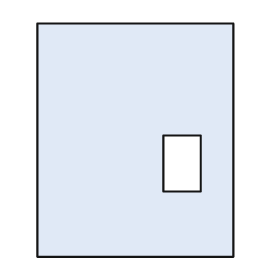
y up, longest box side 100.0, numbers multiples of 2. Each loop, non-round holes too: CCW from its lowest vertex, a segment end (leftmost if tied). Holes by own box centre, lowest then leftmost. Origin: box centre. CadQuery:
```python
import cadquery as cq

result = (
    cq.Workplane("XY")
    .moveTo(-42.0, -50.0)
    .lineTo(42.0, -50.0)
    .lineTo(42.0, 50.0)
    .lineTo(-42.0, 50.0)
    .close()
    .moveTo(12.0, -22.0)
    .lineTo(28.0, -22.0)
    .lineTo(28.0, 2.0)
    .lineTo(12.0, 2.0)
    .close()
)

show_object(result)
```